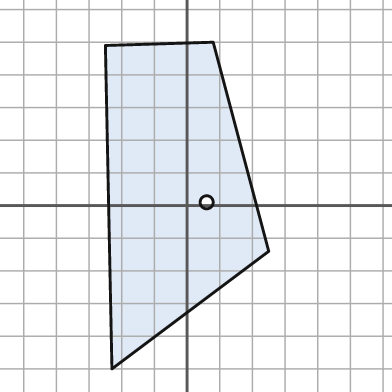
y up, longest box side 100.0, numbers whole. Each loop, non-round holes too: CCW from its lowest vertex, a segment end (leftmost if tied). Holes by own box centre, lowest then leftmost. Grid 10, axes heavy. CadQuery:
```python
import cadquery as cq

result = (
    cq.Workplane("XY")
    .moveTo(-23.0, -50.0)
    .lineTo(25.0, -14.0)
    .lineTo(8.0, 50.0)
    .lineTo(-25.0, 49.0)
    .close()
    .moveTo(6.0, 1.0)
    .circle(2.0)
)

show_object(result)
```